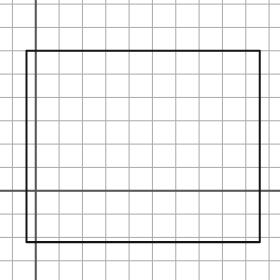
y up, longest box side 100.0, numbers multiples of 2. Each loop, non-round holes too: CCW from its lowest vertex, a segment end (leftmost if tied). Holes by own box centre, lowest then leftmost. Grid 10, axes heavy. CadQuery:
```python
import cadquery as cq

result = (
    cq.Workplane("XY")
    .moveTo(-4.0, -22.0)
    .lineTo(96.0, -22.0)
    .lineTo(96.0, 60.0)
    .lineTo(-4.0, 60.0)
    .close()
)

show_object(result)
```